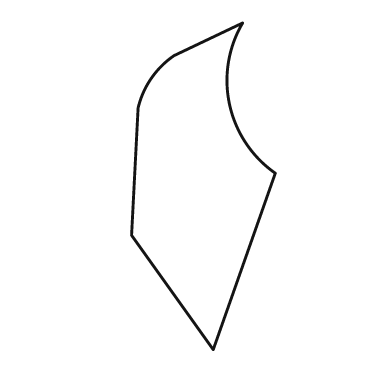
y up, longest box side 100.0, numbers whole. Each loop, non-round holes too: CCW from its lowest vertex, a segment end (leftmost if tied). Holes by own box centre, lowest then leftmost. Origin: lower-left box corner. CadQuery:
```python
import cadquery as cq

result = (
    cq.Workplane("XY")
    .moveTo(25.0, 0.0)
    .lineTo(44.0, 54.0)
    .threePointArc((30.0, 75.0), (34.0, 100.0))
    .lineTo(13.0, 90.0)
    .threePointArc((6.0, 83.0), (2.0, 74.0))
    .lineTo(0.0, 35.0)
    .close()
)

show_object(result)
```